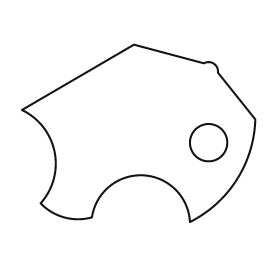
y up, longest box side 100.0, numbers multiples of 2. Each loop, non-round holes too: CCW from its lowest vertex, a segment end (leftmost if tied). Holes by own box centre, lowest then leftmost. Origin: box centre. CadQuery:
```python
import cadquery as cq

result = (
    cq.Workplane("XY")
    .moveTo(22.0, -38.0)
    .threePointArc((42.0, -20.0), (50.0, 6.0))
    .lineTo(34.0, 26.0)
    .threePointArc((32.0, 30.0), (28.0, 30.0))
    .lineTo(-2.0, 38.0)
    .lineTo(-50.0, 10.0)
    .threePointArc((-36.0, -8.0), (-42.0, -30.0))
    .threePointArc((-32.0, -36.0), (-20.0, -36.0))
    .threePointArc((2.0, -18.0), (22.0, -38.0))
    .close()
    .moveTo(30.0, -4.0)
    .circle(8.0)
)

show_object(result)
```